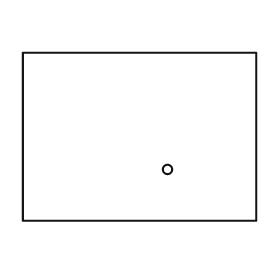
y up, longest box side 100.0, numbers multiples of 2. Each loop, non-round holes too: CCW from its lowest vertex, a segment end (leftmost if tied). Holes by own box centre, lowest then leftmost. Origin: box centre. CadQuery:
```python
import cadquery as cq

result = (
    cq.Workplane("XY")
    .moveTo(-50.0, -36.0)
    .lineTo(50.0, -36.0)
    .lineTo(50.0, 36.0)
    .lineTo(-50.0, 36.0)
    .close()
    .moveTo(12.0, -14.0)
    .circle(2.0)
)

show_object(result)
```